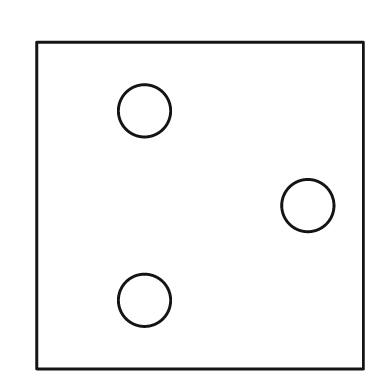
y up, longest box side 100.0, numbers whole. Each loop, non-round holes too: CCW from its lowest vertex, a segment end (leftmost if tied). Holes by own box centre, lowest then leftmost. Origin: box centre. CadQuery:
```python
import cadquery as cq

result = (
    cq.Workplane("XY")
    .moveTo(-50.0, -50.0)
    .lineTo(50.0, -50.0)
    .lineTo(50.0, 50.0)
    .lineTo(-50.0, 50.0)
    .close()
    .moveTo(-17.0, -29.0)
    .circle(8.0)
    .moveTo(33.0, 0.0)
    .circle(8.0)
    .moveTo(-17.0, 29.0)
    .circle(8.0)
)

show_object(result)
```